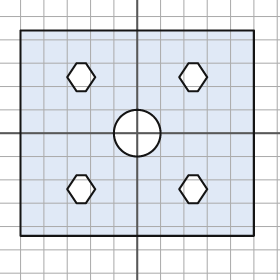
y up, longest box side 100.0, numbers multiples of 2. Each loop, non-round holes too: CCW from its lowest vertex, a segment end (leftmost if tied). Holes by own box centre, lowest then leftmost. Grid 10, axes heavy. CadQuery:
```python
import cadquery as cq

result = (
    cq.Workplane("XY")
    .moveTo(-50.0, -44.0)
    .lineTo(50.0, -44.0)
    .lineTo(50.0, 44.0)
    .lineTo(-50.0, 44.0)
    .close()
    .moveTo(-26.0, -30.0)
    .lineTo(-22.0, -30.0)
    .lineTo(-18.0, -24.0)
    .lineTo(-22.0, -18.0)
    .lineTo(-26.0, -18.0)
    .lineTo(-30.0, -24.0)
    .close()
    .moveTo(22.0, -30.0)
    .lineTo(26.0, -30.0)
    .lineTo(30.0, -24.0)
    .lineTo(26.0, -18.0)
    .lineTo(22.0, -18.0)
    .lineTo(18.0, -24.0)
    .close()
    .moveTo(0.0, 0.0)
    .circle(10.0)
    .moveTo(-26.0, 18.0)
    .lineTo(-22.0, 18.0)
    .lineTo(-18.0, 24.0)
    .lineTo(-22.0, 30.0)
    .lineTo(-26.0, 30.0)
    .lineTo(-30.0, 24.0)
    .close()
    .moveTo(22.0, 18.0)
    .lineTo(26.0, 18.0)
    .lineTo(30.0, 24.0)
    .lineTo(26.0, 30.0)
    .lineTo(22.0, 30.0)
    .lineTo(18.0, 24.0)
    .close()
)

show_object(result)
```